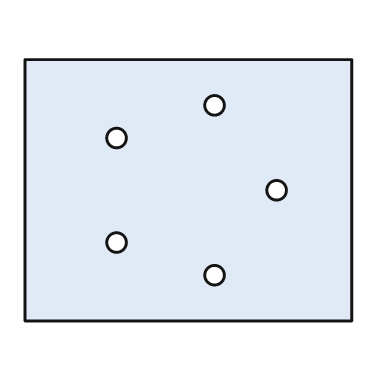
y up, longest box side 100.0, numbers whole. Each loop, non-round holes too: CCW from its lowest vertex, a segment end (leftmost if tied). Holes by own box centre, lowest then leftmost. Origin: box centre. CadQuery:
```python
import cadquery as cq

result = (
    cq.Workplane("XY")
    .moveTo(-50.0, -40.0)
    .lineTo(50.0, -40.0)
    .lineTo(50.0, 40.0)
    .lineTo(-50.0, 40.0)
    .close()
    .moveTo(8.0, -26.0)
    .circle(3.0)
    .moveTo(-22.0, -16.0)
    .circle(3.0)
    .moveTo(27.0, 0.0)
    .circle(3.0)
    .moveTo(-22.0, 16.0)
    .circle(3.0)
    .moveTo(8.0, 26.0)
    .circle(3.0)
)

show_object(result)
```